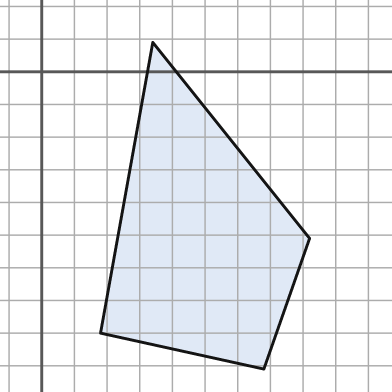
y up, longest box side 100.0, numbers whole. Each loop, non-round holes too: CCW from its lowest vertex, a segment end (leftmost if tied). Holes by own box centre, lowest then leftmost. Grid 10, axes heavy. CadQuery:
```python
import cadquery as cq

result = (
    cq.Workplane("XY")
    .moveTo(68.0, -91.0)
    .lineTo(82.0, -51.0)
    .lineTo(34.0, 9.0)
    .lineTo(18.0, -80.0)
    .close()
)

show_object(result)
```